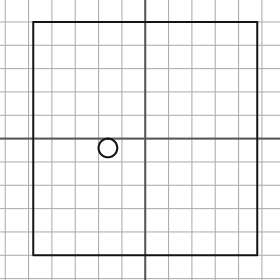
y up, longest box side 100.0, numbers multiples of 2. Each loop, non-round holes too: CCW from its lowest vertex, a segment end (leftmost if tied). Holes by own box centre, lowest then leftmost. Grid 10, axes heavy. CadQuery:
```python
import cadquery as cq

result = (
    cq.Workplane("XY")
    .moveTo(-48.0, -50.0)
    .lineTo(48.0, -50.0)
    .lineTo(48.0, 50.0)
    .lineTo(-48.0, 50.0)
    .close()
    .moveTo(-16.0, -4.0)
    .circle(4.0)
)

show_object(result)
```